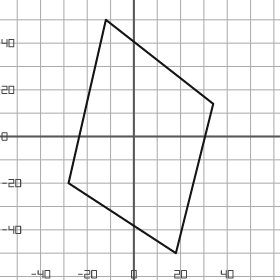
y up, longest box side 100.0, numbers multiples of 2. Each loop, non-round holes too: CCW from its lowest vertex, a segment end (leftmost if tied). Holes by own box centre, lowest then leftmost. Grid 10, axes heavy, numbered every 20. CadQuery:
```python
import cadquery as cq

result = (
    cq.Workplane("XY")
    .moveTo(18.0, -50.0)
    .lineTo(34.0, 14.0)
    .lineTo(-12.0, 50.0)
    .lineTo(-28.0, -20.0)
    .close()
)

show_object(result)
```